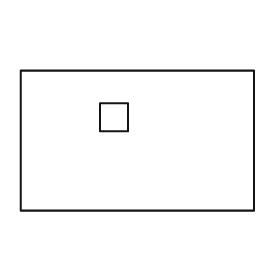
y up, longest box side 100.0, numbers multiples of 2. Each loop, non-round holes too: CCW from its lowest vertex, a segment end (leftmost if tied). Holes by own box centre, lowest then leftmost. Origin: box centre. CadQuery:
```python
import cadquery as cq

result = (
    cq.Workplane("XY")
    .moveTo(-50.0, -30.0)
    .lineTo(50.0, -30.0)
    .lineTo(50.0, 30.0)
    .lineTo(-50.0, 30.0)
    .close()
    .moveTo(-16.0, 4.0)
    .lineTo(-4.0, 4.0)
    .lineTo(-4.0, 16.0)
    .lineTo(-16.0, 16.0)
    .close()
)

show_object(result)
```